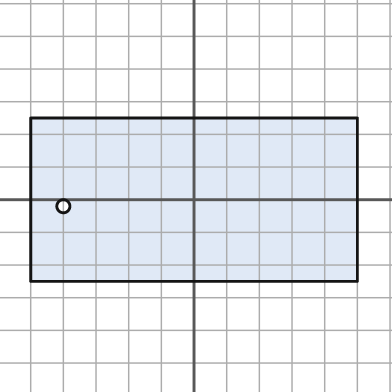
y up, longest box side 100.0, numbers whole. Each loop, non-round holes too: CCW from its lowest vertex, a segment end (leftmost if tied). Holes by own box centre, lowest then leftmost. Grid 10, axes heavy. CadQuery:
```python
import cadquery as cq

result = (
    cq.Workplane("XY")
    .moveTo(-50.0, -25.0)
    .lineTo(50.0, -25.0)
    .lineTo(50.0, 25.0)
    .lineTo(-50.0, 25.0)
    .close()
    .moveTo(-40.0, -2.0)
    .circle(2.0)
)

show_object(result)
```